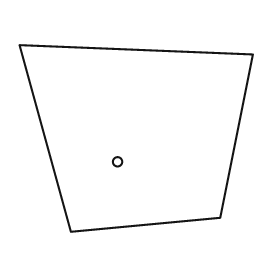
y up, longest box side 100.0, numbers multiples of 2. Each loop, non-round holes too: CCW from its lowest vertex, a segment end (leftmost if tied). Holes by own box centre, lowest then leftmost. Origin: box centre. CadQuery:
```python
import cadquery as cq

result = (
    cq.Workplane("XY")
    .moveTo(-28.0, -40.0)
    .lineTo(36.0, -34.0)
    .lineTo(50.0, 36.0)
    .lineTo(-50.0, 40.0)
    .close()
    .moveTo(-8.0, -10.0)
    .circle(2.0)
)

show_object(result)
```